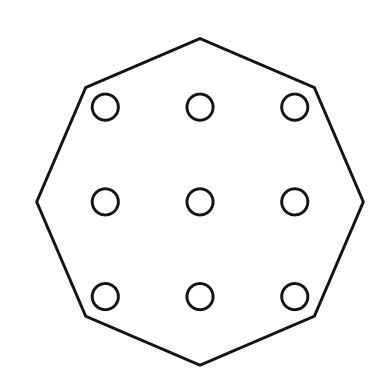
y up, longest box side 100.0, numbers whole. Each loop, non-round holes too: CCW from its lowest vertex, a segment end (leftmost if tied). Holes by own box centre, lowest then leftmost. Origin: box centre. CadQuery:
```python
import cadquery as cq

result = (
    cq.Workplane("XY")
    .moveTo(0.0, -50.0)
    .lineTo(35.0, -35.0)
    .lineTo(50.0, 0.0)
    .lineTo(35.0, 35.0)
    .lineTo(0.0, 50.0)
    .lineTo(-35.0, 35.0)
    .lineTo(-50.0, 0.0)
    .lineTo(-35.0, -35.0)
    .close()
    .moveTo(-29.0, -29.0)
    .circle(4.0)
    .moveTo(0.0, -29.0)
    .circle(4.0)
    .moveTo(29.0, -29.0)
    .circle(4.0)
    .moveTo(-29.0, 0.0)
    .circle(4.0)
    .moveTo(0.0, 0.0)
    .circle(4.0)
    .moveTo(29.0, 0.0)
    .circle(4.0)
    .moveTo(-29.0, 29.0)
    .circle(4.0)
    .moveTo(0.0, 29.0)
    .circle(4.0)
    .moveTo(29.0, 29.0)
    .circle(4.0)
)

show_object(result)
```